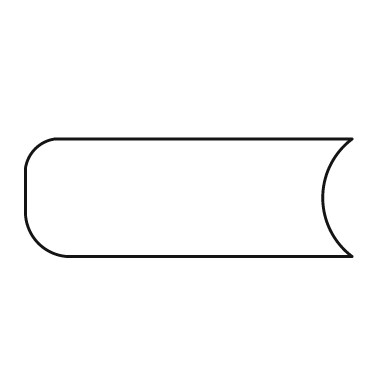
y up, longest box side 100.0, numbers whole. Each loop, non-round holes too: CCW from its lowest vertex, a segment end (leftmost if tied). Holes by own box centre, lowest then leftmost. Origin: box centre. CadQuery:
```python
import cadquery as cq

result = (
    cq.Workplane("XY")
    .moveTo(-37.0, -18.0)
    .lineTo(50.0, -18.0)
    .threePointArc((41.0, 0.0), (50.0, 18.0))
    .lineTo(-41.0, 18.0)
    .threePointArc((-47.0, 15.0), (-50.0, 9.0))
    .lineTo(-50.0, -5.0)
    .threePointArc((-46.0, -14.0), (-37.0, -18.0))
    .close()
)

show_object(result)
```